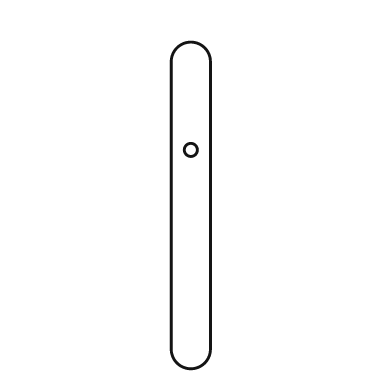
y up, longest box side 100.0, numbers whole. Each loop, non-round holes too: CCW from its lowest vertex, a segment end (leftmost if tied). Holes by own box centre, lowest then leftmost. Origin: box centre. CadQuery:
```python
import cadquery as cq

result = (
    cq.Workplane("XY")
    .moveTo(-6.0, -44.0)
    .threePointArc((0.0, -50.0), (6.0, -44.0))
    .lineTo(6.0, 44.0)
    .threePointArc((0.0, 50.0), (-6.0, 44.0))
    .close()
    .moveTo(0.0, 17.0)
    .circle(2.0)
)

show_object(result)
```